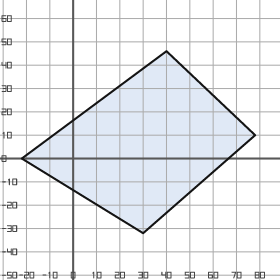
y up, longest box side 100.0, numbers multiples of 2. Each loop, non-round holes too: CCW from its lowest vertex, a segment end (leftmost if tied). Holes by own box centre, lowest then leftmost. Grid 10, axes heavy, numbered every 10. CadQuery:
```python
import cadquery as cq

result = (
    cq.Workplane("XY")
    .moveTo(30.0, -32.0)
    .lineTo(78.0, 10.0)
    .lineTo(40.0, 46.0)
    .lineTo(-22.0, 0.0)
    .close()
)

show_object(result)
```